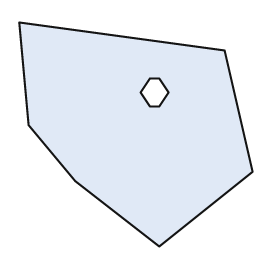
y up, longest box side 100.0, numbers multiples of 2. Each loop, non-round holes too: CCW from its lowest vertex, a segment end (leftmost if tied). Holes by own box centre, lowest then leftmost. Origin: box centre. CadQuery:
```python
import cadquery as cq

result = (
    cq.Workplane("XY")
    .moveTo(10.0, -48.0)
    .lineTo(50.0, -16.0)
    .lineTo(38.0, 36.0)
    .lineTo(-50.0, 48.0)
    .lineTo(-46.0, 4.0)
    .lineTo(-26.0, -20.0)
    .close()
    .moveTo(6.0, 12.0)
    .lineTo(10.0, 12.0)
    .lineTo(14.0, 18.0)
    .lineTo(10.0, 24.0)
    .lineTo(6.0, 24.0)
    .lineTo(2.0, 18.0)
    .close()
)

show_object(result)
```